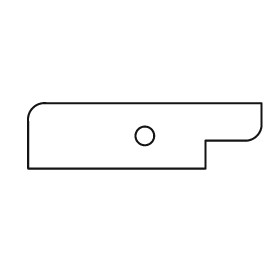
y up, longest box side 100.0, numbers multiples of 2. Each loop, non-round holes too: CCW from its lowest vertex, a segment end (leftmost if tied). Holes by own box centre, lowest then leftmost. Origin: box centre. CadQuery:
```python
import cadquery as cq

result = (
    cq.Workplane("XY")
    .moveTo(-50.0, -14.0)
    .lineTo(26.0, -14.0)
    .lineTo(26.0, -2.0)
    .lineTo(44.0, -2.0)
    .threePointArc((48.0, 0.0), (50.0, 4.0))
    .lineTo(50.0, 14.0)
    .lineTo(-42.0, 14.0)
    .threePointArc((-48.0, 12.0), (-50.0, 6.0))
    .close()
    .moveTo(0.0, 0.0)
    .circle(4.0)
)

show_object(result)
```